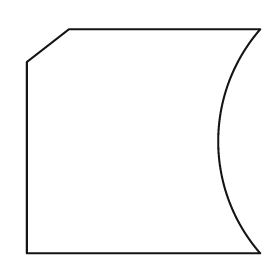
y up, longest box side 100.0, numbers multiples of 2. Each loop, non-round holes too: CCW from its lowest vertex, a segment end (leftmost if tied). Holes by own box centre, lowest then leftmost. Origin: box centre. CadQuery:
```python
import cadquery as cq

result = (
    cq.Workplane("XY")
    .moveTo(-50.0, -48.0)
    .lineTo(50.0, -48.0)
    .threePointArc((32.0, 0.0), (50.0, 48.0))
    .lineTo(-32.0, 48.0)
    .lineTo(-50.0, 34.0)
    .close()
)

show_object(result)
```